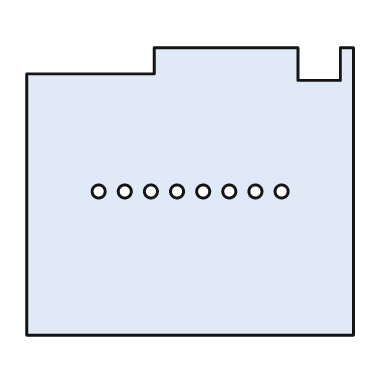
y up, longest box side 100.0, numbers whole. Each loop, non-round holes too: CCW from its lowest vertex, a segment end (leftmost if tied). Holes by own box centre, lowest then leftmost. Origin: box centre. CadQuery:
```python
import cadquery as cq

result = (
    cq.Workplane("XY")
    .moveTo(-50.0, -44.0)
    .lineTo(50.0, -44.0)
    .lineTo(50.0, 44.0)
    .lineTo(46.0, 44.0)
    .lineTo(46.0, 34.0)
    .lineTo(33.0, 34.0)
    .lineTo(33.0, 44.0)
    .lineTo(-11.0, 44.0)
    .lineTo(-11.0, 36.0)
    .lineTo(-50.0, 36.0)
    .close()
    .moveTo(-28.0, 0.0)
    .circle(2.0)
    .moveTo(-20.0, 0.0)
    .circle(2.0)
    .moveTo(-12.0, 0.0)
    .circle(2.0)
    .moveTo(-4.0, 0.0)
    .circle(2.0)
    .moveTo(4.0, 0.0)
    .circle(2.0)
    .moveTo(12.0, 0.0)
    .circle(2.0)
    .moveTo(20.0, 0.0)
    .circle(2.0)
    .moveTo(28.0, 0.0)
    .circle(2.0)
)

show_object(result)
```